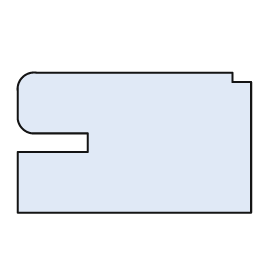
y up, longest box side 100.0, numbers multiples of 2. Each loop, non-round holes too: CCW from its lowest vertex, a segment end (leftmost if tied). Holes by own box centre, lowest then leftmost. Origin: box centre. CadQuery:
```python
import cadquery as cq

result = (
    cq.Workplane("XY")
    .moveTo(-50.0, -30.0)
    .lineTo(50.0, -30.0)
    .lineTo(50.0, 26.0)
    .lineTo(42.0, 26.0)
    .lineTo(42.0, 30.0)
    .lineTo(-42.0, 30.0)
    .threePointArc((-48.0, 28.0), (-50.0, 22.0))
    .lineTo(-50.0, 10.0)
    .threePointArc((-48.0, 6.0), (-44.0, 4.0))
    .lineTo(-20.0, 4.0)
    .lineTo(-20.0, -4.0)
    .lineTo(-50.0, -4.0)
    .close()
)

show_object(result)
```